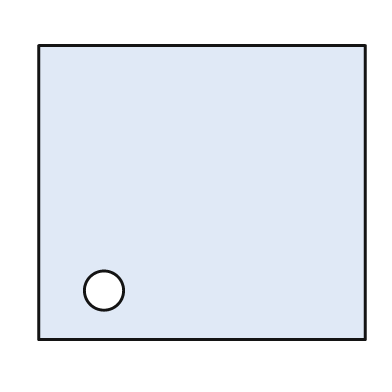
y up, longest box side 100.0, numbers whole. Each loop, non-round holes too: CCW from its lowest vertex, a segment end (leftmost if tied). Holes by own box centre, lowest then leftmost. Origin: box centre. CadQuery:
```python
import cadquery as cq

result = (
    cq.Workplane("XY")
    .moveTo(-50.0, -45.0)
    .lineTo(50.0, -45.0)
    .lineTo(50.0, 45.0)
    .lineTo(-50.0, 45.0)
    .close()
    .moveTo(-30.0, -30.0)
    .circle(6.0)
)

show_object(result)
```